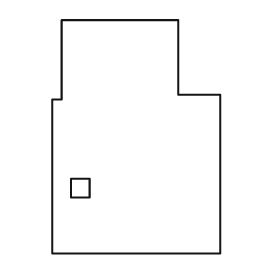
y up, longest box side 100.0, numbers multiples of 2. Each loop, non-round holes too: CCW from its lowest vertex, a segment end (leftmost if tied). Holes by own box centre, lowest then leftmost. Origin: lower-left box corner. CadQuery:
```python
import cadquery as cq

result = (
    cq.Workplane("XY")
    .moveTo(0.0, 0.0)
    .lineTo(72.0, 0.0)
    .lineTo(72.0, 68.0)
    .lineTo(54.0, 68.0)
    .lineTo(54.0, 100.0)
    .lineTo(4.0, 100.0)
    .lineTo(4.0, 66.0)
    .lineTo(0.0, 66.0)
    .close()
    .moveTo(8.0, 24.0)
    .lineTo(16.0, 24.0)
    .lineTo(16.0, 32.0)
    .lineTo(8.0, 32.0)
    .close()
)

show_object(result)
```